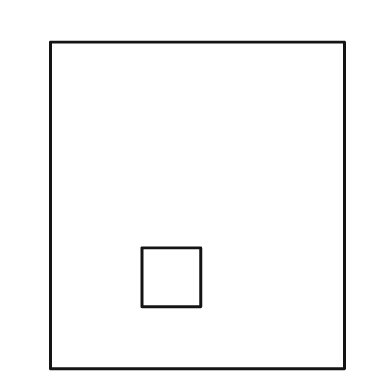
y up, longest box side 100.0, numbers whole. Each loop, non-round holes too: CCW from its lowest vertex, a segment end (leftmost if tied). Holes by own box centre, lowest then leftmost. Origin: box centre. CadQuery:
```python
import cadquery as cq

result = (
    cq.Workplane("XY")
    .moveTo(-45.0, -50.0)
    .lineTo(45.0, -50.0)
    .lineTo(45.0, 50.0)
    .lineTo(-45.0, 50.0)
    .close()
    .moveTo(-17.0, -31.0)
    .lineTo(1.0, -31.0)
    .lineTo(1.0, -13.0)
    .lineTo(-17.0, -13.0)
    .close()
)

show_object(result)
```